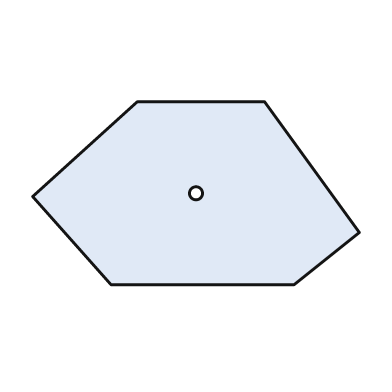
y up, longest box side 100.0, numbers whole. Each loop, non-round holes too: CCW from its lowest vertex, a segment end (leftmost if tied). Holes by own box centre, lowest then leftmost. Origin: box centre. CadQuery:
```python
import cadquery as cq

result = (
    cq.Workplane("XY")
    .moveTo(-26.0, -28.0)
    .lineTo(30.0, -28.0)
    .lineTo(50.0, -12.0)
    .lineTo(21.0, 28.0)
    .lineTo(-18.0, 28.0)
    .lineTo(-50.0, -1.0)
    .close()
    .moveTo(0.0, 0.0)
    .circle(2.0)
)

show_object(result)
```